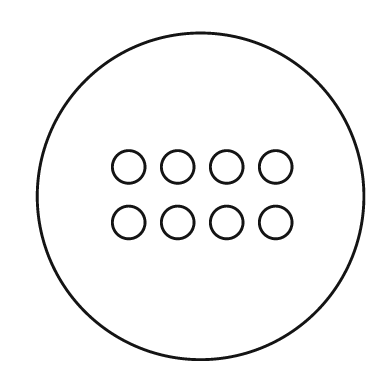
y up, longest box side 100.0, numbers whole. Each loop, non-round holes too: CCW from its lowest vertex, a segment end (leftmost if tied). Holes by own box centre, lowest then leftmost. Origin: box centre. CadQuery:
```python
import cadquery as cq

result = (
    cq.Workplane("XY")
    .moveTo(0.0, 0.0)
    .circle(50.0)
    .moveTo(-22.0, -8.0)
    .circle(5.0)
    .moveTo(-7.0, -8.0)
    .circle(5.0)
    .moveTo(8.0, -8.0)
    .circle(5.0)
    .moveTo(23.0, -8.0)
    .circle(5.0)
    .moveTo(-22.0, 9.0)
    .circle(5.0)
    .moveTo(-7.0, 9.0)
    .circle(5.0)
    .moveTo(8.0, 9.0)
    .circle(5.0)
    .moveTo(23.0, 9.0)
    .circle(5.0)
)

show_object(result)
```